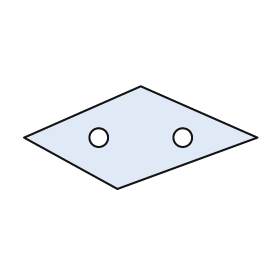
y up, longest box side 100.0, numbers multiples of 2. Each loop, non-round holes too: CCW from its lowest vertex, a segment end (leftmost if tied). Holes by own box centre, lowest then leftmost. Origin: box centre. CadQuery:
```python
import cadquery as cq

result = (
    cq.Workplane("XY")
    .moveTo(-10.0, -22.0)
    .lineTo(50.0, 0.0)
    .lineTo(0.0, 22.0)
    .lineTo(-50.0, 0.0)
    .close()
    .moveTo(-18.0, 0.0)
    .circle(4.0)
    .moveTo(18.0, 0.0)
    .circle(4.0)
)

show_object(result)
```